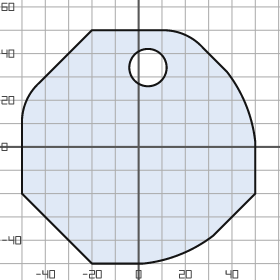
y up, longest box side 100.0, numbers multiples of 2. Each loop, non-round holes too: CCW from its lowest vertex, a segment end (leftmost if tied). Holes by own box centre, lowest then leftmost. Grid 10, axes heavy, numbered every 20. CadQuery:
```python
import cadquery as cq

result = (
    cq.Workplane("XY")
    .moveTo(-20.0, -50.0)
    .lineTo(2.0, -50.0)
    .threePointArc((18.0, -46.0), (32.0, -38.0))
    .lineTo(50.0, -20.0)
    .lineTo(50.0, 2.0)
    .threePointArc((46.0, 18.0), (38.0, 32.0))
    .lineTo(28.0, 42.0)
    .threePointArc((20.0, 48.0), (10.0, 50.0))
    .lineTo(-20.0, 50.0)
    .lineTo(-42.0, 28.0)
    .threePointArc((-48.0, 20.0), (-50.0, 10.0))
    .lineTo(-50.0, -20.0)
    .close()
    .moveTo(4.0, 34.0)
    .circle(8.0)
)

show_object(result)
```